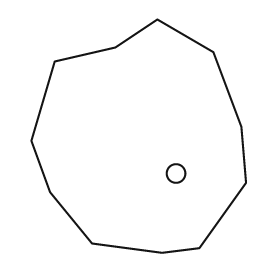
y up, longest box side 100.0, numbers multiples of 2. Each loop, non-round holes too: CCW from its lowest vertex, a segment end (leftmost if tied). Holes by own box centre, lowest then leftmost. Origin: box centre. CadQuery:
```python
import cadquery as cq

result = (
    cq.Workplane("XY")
    .moveTo(10.0, -50.0)
    .lineTo(26.0, -48.0)
    .lineTo(46.0, -20.0)
    .lineTo(44.0, 4.0)
    .lineTo(32.0, 36.0)
    .lineTo(8.0, 50.0)
    .lineTo(-10.0, 38.0)
    .lineTo(-36.0, 32.0)
    .lineTo(-46.0, -2.0)
    .lineTo(-38.0, -24.0)
    .lineTo(-20.0, -46.0)
    .close()
    .moveTo(16.0, -16.0)
    .circle(4.0)
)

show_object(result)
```